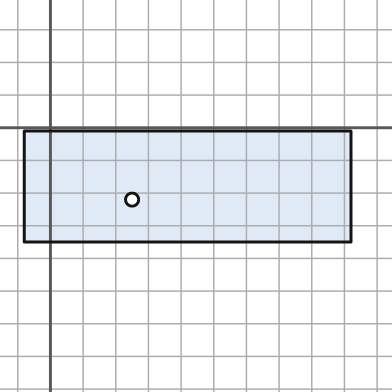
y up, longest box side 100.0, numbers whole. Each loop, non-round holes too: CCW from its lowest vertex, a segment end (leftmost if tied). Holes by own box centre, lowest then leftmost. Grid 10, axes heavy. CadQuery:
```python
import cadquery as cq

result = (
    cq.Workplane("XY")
    .moveTo(-8.0, -35.0)
    .lineTo(92.0, -35.0)
    .lineTo(92.0, -1.0)
    .lineTo(-8.0, -1.0)
    .close()
    .moveTo(25.0, -22.0)
    .circle(2.0)
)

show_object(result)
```